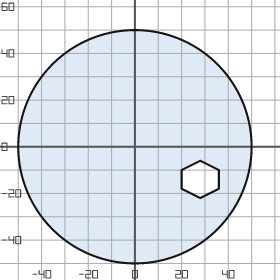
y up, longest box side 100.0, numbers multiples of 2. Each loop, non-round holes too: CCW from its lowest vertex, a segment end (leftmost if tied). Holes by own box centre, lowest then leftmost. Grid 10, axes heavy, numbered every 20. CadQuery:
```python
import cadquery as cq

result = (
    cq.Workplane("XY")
    .moveTo(0.0, 0.0)
    .circle(50.0)
    .moveTo(28.0, -22.0)
    .lineTo(36.0, -18.0)
    .lineTo(36.0, -10.0)
    .lineTo(28.0, -6.0)
    .lineTo(20.0, -10.0)
    .lineTo(20.0, -18.0)
    .close()
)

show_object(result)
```